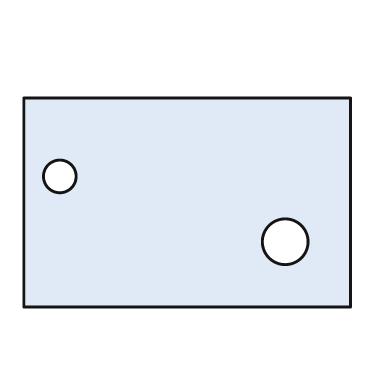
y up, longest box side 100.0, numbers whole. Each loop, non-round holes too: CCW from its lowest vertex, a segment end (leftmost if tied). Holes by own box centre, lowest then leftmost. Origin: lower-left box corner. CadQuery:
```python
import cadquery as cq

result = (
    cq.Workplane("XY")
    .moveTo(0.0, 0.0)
    .lineTo(100.0, 0.0)
    .lineTo(100.0, 64.0)
    .lineTo(0.0, 64.0)
    .close()
    .moveTo(80.0, 20.0)
    .circle(7.0)
    .moveTo(11.0, 40.0)
    .circle(5.0)
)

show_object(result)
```